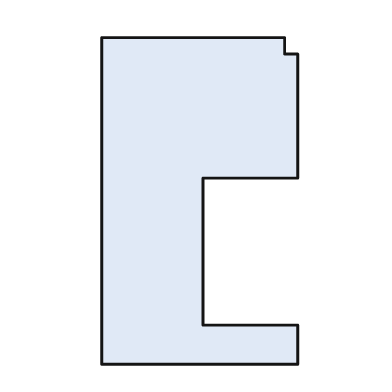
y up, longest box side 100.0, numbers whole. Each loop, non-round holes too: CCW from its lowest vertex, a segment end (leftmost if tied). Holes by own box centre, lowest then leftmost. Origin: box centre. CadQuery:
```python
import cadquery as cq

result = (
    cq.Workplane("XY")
    .moveTo(-30.0, -50.0)
    .lineTo(30.0, -50.0)
    .lineTo(30.0, -38.0)
    .lineTo(1.0, -38.0)
    .lineTo(1.0, 7.0)
    .lineTo(30.0, 7.0)
    .lineTo(30.0, 45.0)
    .lineTo(26.0, 45.0)
    .lineTo(26.0, 50.0)
    .lineTo(-30.0, 50.0)
    .close()
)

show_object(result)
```